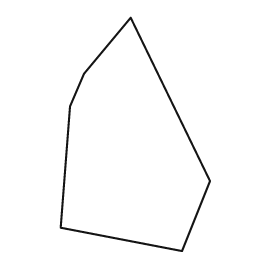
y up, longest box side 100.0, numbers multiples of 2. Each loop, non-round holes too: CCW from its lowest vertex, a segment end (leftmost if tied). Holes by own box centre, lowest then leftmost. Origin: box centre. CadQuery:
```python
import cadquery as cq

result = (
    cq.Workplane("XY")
    .moveTo(20.0, -50.0)
    .lineTo(32.0, -20.0)
    .lineTo(-2.0, 50.0)
    .lineTo(-22.0, 26.0)
    .lineTo(-28.0, 12.0)
    .lineTo(-32.0, -40.0)
    .close()
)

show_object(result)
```